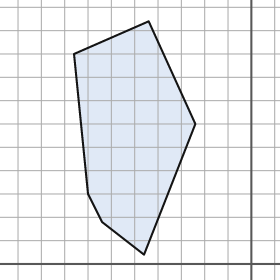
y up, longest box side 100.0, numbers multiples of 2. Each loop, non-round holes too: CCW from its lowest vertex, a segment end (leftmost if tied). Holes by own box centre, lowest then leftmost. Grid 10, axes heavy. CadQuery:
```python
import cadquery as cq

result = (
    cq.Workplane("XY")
    .moveTo(-46.0, 4.0)
    .lineTo(-24.0, 60.0)
    .lineTo(-44.0, 104.0)
    .lineTo(-76.0, 90.0)
    .lineTo(-70.0, 30.0)
    .lineTo(-64.0, 18.0)
    .close()
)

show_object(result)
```